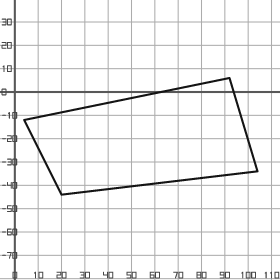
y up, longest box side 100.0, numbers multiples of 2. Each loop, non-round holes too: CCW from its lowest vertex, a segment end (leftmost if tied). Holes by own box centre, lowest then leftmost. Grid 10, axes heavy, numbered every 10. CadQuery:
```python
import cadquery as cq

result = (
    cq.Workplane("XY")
    .moveTo(20.0, -44.0)
    .lineTo(104.0, -34.0)
    .lineTo(92.0, 6.0)
    .lineTo(4.0, -12.0)
    .close()
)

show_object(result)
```